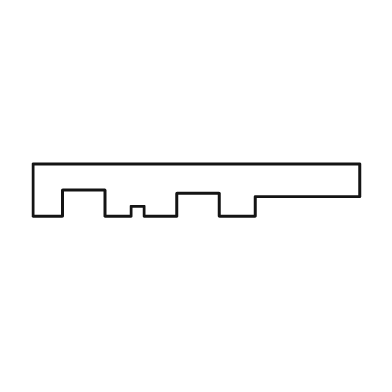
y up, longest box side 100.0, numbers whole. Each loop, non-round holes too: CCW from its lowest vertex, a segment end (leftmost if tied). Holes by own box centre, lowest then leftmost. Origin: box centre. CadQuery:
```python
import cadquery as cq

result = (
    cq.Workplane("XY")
    .moveTo(-50.0, -8.0)
    .lineTo(-41.0, -8.0)
    .lineTo(-41.0, 0.0)
    .lineTo(-28.0, 0.0)
    .lineTo(-28.0, -8.0)
    .lineTo(-20.0, -8.0)
    .lineTo(-20.0, -5.0)
    .lineTo(-16.0, -5.0)
    .lineTo(-16.0, -8.0)
    .lineTo(-6.0, -8.0)
    .lineTo(-6.0, -1.0)
    .lineTo(7.0, -1.0)
    .lineTo(7.0, -8.0)
    .lineTo(18.0, -8.0)
    .lineTo(18.0, -2.0)
    .lineTo(50.0, -2.0)
    .lineTo(50.0, 8.0)
    .lineTo(-50.0, 8.0)
    .close()
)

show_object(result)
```